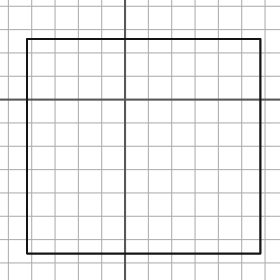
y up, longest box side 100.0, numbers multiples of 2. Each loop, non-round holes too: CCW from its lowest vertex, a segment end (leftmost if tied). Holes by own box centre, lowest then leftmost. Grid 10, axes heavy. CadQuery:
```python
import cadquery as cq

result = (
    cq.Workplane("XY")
    .moveTo(-42.0, -66.0)
    .lineTo(58.0, -66.0)
    .lineTo(58.0, 26.0)
    .lineTo(-42.0, 26.0)
    .close()
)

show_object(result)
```